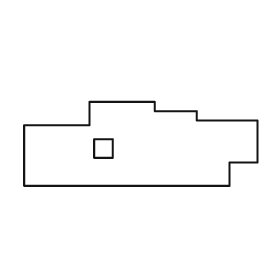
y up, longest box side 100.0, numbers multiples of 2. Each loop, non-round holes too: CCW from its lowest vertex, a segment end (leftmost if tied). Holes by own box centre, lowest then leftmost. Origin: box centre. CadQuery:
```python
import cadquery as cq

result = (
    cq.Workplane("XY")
    .moveTo(-50.0, -18.0)
    .lineTo(38.0, -18.0)
    .lineTo(38.0, -8.0)
    .lineTo(50.0, -8.0)
    .lineTo(50.0, 10.0)
    .lineTo(24.0, 10.0)
    .lineTo(24.0, 14.0)
    .lineTo(6.0, 14.0)
    .lineTo(6.0, 18.0)
    .lineTo(-22.0, 18.0)
    .lineTo(-22.0, 8.0)
    .lineTo(-50.0, 8.0)
    .close()
    .moveTo(-20.0, -6.0)
    .lineTo(-12.0, -6.0)
    .lineTo(-12.0, 2.0)
    .lineTo(-20.0, 2.0)
    .close()
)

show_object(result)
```